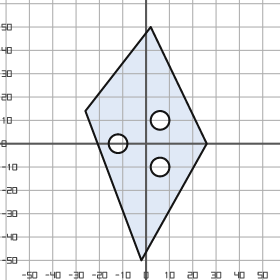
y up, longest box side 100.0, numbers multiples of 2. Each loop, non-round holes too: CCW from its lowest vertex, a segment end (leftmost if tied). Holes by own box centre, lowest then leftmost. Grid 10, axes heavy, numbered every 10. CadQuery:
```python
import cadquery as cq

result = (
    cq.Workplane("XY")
    .moveTo(-2.0, -50.0)
    .lineTo(26.0, 0.0)
    .lineTo(2.0, 50.0)
    .lineTo(-26.0, 14.0)
    .close()
    .moveTo(6.0, -10.0)
    .circle(4.0)
    .moveTo(-12.0, 0.0)
    .circle(4.0)
    .moveTo(6.0, 10.0)
    .circle(4.0)
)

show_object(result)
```